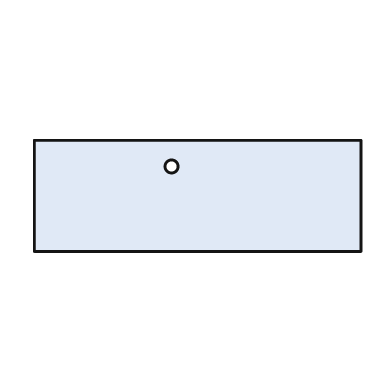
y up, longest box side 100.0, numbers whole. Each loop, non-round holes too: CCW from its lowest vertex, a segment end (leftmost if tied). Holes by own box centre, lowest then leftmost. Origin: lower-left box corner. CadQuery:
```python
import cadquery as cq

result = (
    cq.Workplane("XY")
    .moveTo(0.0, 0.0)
    .lineTo(100.0, 0.0)
    .lineTo(100.0, 34.0)
    .lineTo(0.0, 34.0)
    .close()
    .moveTo(42.0, 26.0)
    .circle(2.0)
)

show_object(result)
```